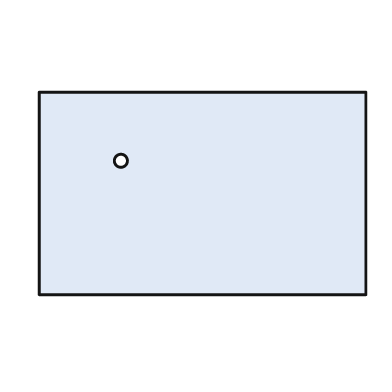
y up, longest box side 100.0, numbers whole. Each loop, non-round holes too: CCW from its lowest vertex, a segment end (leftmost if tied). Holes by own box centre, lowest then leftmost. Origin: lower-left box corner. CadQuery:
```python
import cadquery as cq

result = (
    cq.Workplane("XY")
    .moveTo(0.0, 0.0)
    .lineTo(100.0, 0.0)
    .lineTo(100.0, 62.0)
    .lineTo(0.0, 62.0)
    .close()
    .moveTo(25.0, 41.0)
    .circle(2.0)
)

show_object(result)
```